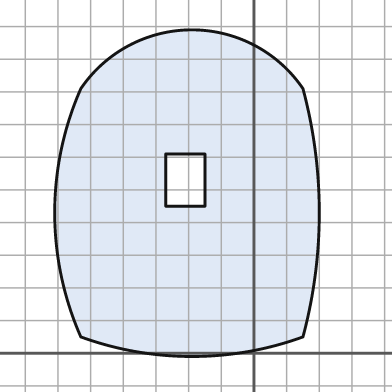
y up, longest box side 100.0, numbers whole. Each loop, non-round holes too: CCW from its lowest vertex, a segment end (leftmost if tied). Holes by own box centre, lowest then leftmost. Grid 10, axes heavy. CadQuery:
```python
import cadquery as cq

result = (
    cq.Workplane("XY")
    .moveTo(-53.0, 5.0)
    .threePointArc((-19.0, -1.0), (15.0, 5.0))
    .threePointArc((20.0, 43.0), (15.0, 81.0))
    .threePointArc((-19.0, 99.0), (-53.0, 81.0))
    .threePointArc((-61.0, 43.0), (-53.0, 5.0))
    .close()
    .moveTo(-27.0, 45.0)
    .lineTo(-15.0, 45.0)
    .lineTo(-15.0, 61.0)
    .lineTo(-27.0, 61.0)
    .close()
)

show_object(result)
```